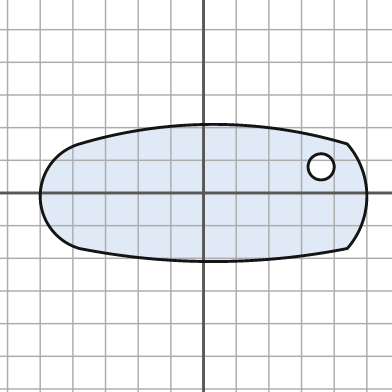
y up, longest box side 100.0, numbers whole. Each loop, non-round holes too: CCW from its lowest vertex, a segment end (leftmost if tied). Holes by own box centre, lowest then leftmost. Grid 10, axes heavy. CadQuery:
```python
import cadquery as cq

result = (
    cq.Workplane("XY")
    .moveTo(-38.0, -17.0)
    .threePointArc((3.0, -21.0), (44.0, -17.0))
    .threePointArc((50.0, -1.0), (44.0, 15.0))
    .threePointArc((3.0, 21.0), (-38.0, 15.0))
    .threePointArc((-50.0, -1.0), (-38.0, -17.0))
    .close()
    .moveTo(36.0, 8.0)
    .circle(4.0)
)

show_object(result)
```